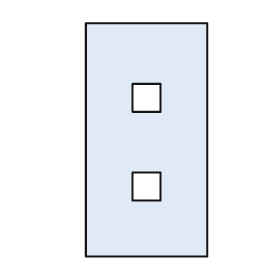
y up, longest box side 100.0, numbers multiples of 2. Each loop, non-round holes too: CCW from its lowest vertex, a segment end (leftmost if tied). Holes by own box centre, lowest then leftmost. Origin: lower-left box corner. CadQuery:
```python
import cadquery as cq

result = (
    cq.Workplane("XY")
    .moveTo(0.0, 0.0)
    .lineTo(52.0, 0.0)
    .lineTo(52.0, 100.0)
    .lineTo(0.0, 100.0)
    .close()
    .moveTo(20.0, 24.0)
    .lineTo(32.0, 24.0)
    .lineTo(32.0, 36.0)
    .lineTo(20.0, 36.0)
    .close()
    .moveTo(20.0, 62.0)
    .lineTo(32.0, 62.0)
    .lineTo(32.0, 74.0)
    .lineTo(20.0, 74.0)
    .close()
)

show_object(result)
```